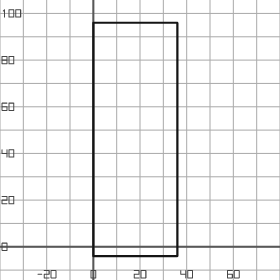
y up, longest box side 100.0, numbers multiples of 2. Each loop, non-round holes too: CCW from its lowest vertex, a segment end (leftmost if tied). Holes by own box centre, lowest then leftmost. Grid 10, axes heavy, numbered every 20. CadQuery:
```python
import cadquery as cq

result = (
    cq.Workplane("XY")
    .moveTo(0.0, -4.0)
    .lineTo(36.0, -4.0)
    .lineTo(36.0, 96.0)
    .lineTo(0.0, 96.0)
    .close()
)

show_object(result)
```